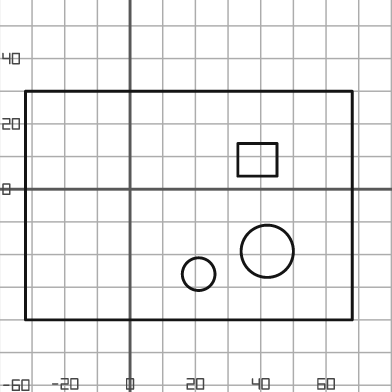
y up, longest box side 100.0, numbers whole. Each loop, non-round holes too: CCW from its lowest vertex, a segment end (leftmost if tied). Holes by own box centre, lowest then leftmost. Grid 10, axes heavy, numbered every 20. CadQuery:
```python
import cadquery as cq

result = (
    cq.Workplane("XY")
    .moveTo(-32.0, -40.0)
    .lineTo(68.0, -40.0)
    .lineTo(68.0, 30.0)
    .lineTo(-32.0, 30.0)
    .close()
    .moveTo(21.0, -26.0)
    .circle(5.0)
    .moveTo(42.0, -19.0)
    .circle(8.0)
    .moveTo(33.0, 4.0)
    .lineTo(45.0, 4.0)
    .lineTo(45.0, 14.0)
    .lineTo(33.0, 14.0)
    .close()
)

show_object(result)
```